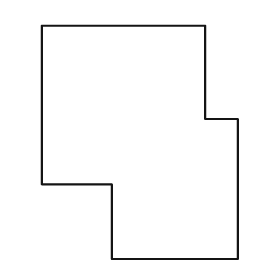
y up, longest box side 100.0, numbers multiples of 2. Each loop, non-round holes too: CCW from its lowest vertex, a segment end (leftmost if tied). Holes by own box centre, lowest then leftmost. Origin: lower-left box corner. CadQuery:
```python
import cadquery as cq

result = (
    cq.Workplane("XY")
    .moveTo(30.0, 0.0)
    .lineTo(84.0, 0.0)
    .lineTo(84.0, 60.0)
    .lineTo(70.0, 60.0)
    .lineTo(70.0, 100.0)
    .lineTo(0.0, 100.0)
    .lineTo(0.0, 32.0)
    .lineTo(30.0, 32.0)
    .close()
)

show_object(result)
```